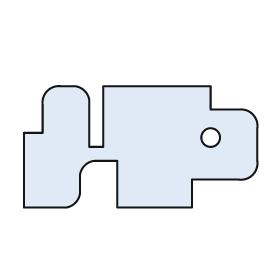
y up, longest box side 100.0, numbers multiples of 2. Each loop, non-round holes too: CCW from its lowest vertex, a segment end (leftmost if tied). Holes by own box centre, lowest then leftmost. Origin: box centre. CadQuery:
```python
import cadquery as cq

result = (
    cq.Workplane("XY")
    .moveTo(-50.0, -26.0)
    .lineTo(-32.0, -26.0)
    .threePointArc((-28.0, -24.0), (-26.0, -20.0))
    .lineTo(-26.0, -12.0)
    .threePointArc((-24.0, -8.0), (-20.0, -6.0))
    .lineTo(-10.0, -6.0)
    .lineTo(-10.0, -26.0)
    .lineTo(22.0, -26.0)
    .lineTo(22.0, -14.0)
    .lineTo(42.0, -14.0)
    .threePointArc((48.0, -12.0), (50.0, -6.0))
    .lineTo(50.0, 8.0)
    .threePointArc((48.0, 14.0), (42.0, 16.0))
    .lineTo(30.0, 16.0)
    .lineTo(30.0, 26.0)
    .lineTo(-16.0, 26.0)
    .lineTo(-16.0, 0.0)
    .lineTo(-22.0, 0.0)
    .lineTo(-22.0, 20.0)
    .threePointArc((-24.0, 24.0), (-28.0, 26.0))
    .lineTo(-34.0, 26.0)
    .threePointArc((-40.0, 24.0), (-42.0, 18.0))
    .lineTo(-42.0, 6.0)
    .lineTo(-50.0, 6.0)
    .close()
    .moveTo(30.0, 4.0)
    .circle(4.0)
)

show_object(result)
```